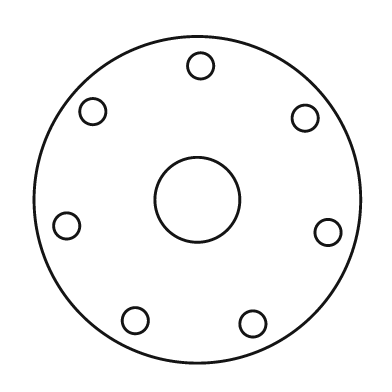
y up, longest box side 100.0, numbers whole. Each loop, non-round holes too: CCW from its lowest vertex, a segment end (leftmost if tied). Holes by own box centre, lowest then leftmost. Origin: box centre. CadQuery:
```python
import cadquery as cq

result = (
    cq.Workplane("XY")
    .moveTo(0.0, 0.0)
    .circle(50.0)
    .moveTo(17.0, -38.0)
    .circle(4.0)
    .moveTo(-19.0, -37.0)
    .circle(4.0)
    .moveTo(40.0, -10.0)
    .circle(4.0)
    .moveTo(-40.0, -8.0)
    .circle(4.0)
    .moveTo(0.0, 0.0)
    .circle(13.0)
    .moveTo(33.0, 25.0)
    .circle(4.0)
    .moveTo(-32.0, 27.0)
    .circle(4.0)
    .moveTo(1.0, 41.0)
    .circle(4.0)
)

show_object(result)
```